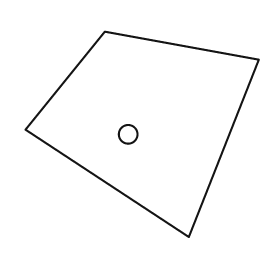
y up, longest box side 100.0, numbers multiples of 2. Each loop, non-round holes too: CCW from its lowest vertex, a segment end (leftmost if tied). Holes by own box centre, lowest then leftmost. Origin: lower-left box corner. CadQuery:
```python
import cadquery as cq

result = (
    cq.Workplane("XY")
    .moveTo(70.0, 0.0)
    .lineTo(100.0, 76.0)
    .lineTo(34.0, 88.0)
    .lineTo(0.0, 46.0)
    .close()
    .moveTo(44.0, 44.0)
    .circle(4.0)
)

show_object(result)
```